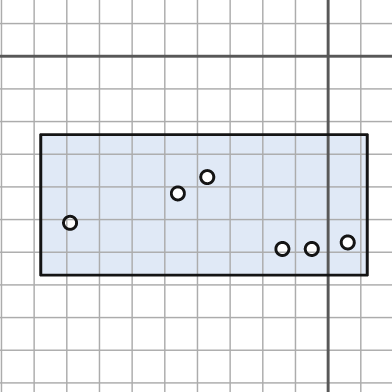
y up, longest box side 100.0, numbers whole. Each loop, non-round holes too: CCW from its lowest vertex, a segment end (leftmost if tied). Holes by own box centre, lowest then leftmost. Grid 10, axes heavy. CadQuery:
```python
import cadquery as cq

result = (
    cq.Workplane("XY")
    .moveTo(-88.0, -67.0)
    .lineTo(12.0, -67.0)
    .lineTo(12.0, -24.0)
    .lineTo(-88.0, -24.0)
    .close()
    .moveTo(-14.0, -59.0)
    .circle(2.0)
    .moveTo(-5.0, -59.0)
    .circle(2.0)
    .moveTo(6.0, -57.0)
    .circle(2.0)
    .moveTo(-79.0, -51.0)
    .circle(2.0)
    .moveTo(-46.0, -42.0)
    .circle(2.0)
    .moveTo(-37.0, -37.0)
    .circle(2.0)
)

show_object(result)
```